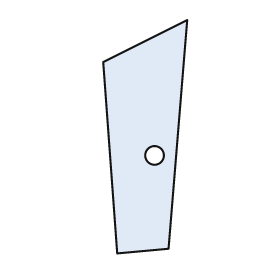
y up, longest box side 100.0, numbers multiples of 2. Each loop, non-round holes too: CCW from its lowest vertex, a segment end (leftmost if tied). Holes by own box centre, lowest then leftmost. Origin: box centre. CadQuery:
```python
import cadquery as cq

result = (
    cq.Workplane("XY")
    .moveTo(-12.0, -50.0)
    .lineTo(10.0, -48.0)
    .lineTo(18.0, 50.0)
    .lineTo(-18.0, 32.0)
    .close()
    .moveTo(4.0, -8.0)
    .circle(4.0)
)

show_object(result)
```